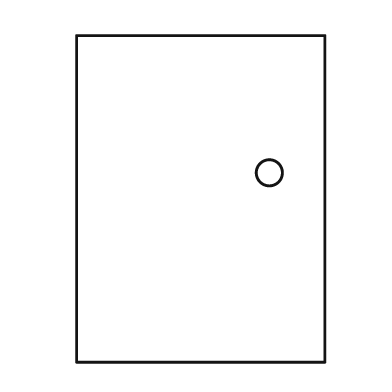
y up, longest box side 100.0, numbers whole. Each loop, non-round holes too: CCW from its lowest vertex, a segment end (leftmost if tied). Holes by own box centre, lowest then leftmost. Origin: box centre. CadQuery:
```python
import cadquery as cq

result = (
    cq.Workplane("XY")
    .moveTo(-38.0, -50.0)
    .lineTo(38.0, -50.0)
    .lineTo(38.0, 50.0)
    .lineTo(-38.0, 50.0)
    .close()
    .moveTo(21.0, 8.0)
    .circle(4.0)
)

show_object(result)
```